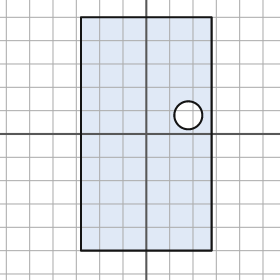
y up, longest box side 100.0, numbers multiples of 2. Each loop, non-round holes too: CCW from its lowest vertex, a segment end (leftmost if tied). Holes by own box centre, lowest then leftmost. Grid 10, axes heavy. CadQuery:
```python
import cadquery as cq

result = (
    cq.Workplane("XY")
    .moveTo(-28.0, -50.0)
    .lineTo(28.0, -50.0)
    .lineTo(28.0, 50.0)
    .lineTo(-28.0, 50.0)
    .close()
    .moveTo(18.0, 8.0)
    .circle(6.0)
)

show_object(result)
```